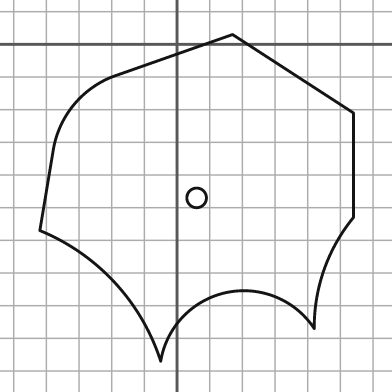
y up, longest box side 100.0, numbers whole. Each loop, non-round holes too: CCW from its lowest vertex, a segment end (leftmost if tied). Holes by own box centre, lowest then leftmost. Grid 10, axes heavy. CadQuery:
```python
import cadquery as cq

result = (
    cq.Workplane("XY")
    .moveTo(-5.0, -97.0)
    .threePointArc((15.0, -76.0), (42.0, -87.0))
    .threePointArc((45.0, -69.0), (54.0, -53.0))
    .lineTo(54.0, -21.0)
    .lineTo(17.0, 3.0)
    .lineTo(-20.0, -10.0)
    .threePointArc((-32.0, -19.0), (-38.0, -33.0))
    .lineTo(-42.0, -57.0)
    .threePointArc((-19.0, -73.0), (-5.0, -97.0))
    .close()
    .moveTo(6.0, -47.0)
    .circle(3.0)
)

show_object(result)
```